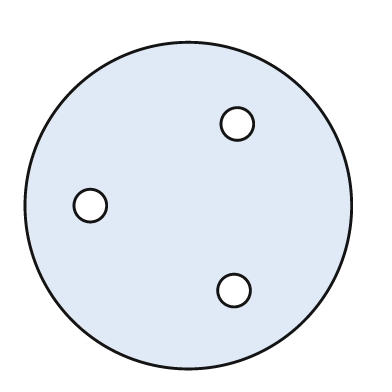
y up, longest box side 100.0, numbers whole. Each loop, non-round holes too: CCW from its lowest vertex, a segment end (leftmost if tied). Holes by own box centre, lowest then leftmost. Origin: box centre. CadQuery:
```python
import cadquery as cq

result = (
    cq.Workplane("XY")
    .moveTo(0.0, 0.0)
    .circle(50.0)
    .moveTo(14.0, -26.0)
    .circle(5.0)
    .moveTo(-30.0, 0.0)
    .circle(5.0)
    .moveTo(15.0, 25.0)
    .circle(5.0)
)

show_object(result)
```